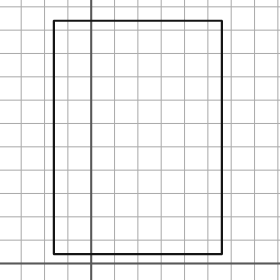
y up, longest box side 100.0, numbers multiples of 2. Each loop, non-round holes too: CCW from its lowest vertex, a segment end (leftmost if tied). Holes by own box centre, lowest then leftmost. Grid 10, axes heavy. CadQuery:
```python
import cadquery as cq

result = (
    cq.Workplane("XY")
    .moveTo(-16.0, 4.0)
    .lineTo(56.0, 4.0)
    .lineTo(56.0, 104.0)
    .lineTo(-16.0, 104.0)
    .close()
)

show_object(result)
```